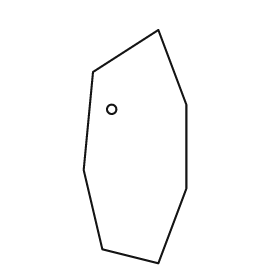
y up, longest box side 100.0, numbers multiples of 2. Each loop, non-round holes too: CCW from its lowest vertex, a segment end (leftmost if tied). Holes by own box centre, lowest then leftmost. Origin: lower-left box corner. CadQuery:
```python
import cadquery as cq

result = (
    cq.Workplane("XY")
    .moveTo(32.0, 0.0)
    .lineTo(44.0, 32.0)
    .lineTo(44.0, 68.0)
    .lineTo(32.0, 100.0)
    .lineTo(4.0, 82.0)
    .lineTo(0.0, 40.0)
    .lineTo(8.0, 6.0)
    .close()
    .moveTo(12.0, 66.0)
    .circle(2.0)
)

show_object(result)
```